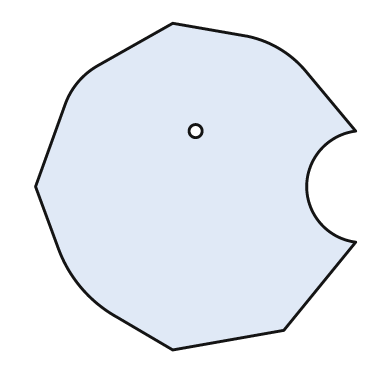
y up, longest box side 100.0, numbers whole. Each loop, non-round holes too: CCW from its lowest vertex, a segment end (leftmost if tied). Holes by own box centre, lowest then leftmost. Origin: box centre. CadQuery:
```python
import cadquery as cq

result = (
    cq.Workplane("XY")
    .moveTo(-7.0, -50.0)
    .lineTo(27.0, -44.0)
    .lineTo(49.0, -17.0)
    .threePointArc((34.0, 0.0), (49.0, 17.0))
    .lineTo(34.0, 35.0)
    .threePointArc((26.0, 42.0), (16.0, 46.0))
    .lineTo(-7.0, 50.0)
    .lineTo(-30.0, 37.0)
    .threePointArc((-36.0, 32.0), (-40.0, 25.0))
    .lineTo(-49.0, 0.0)
    .lineTo(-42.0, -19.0)
    .threePointArc((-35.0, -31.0), (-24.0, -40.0))
    .close()
    .moveTo(0.0, 17.0)
    .circle(2.0)
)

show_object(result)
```